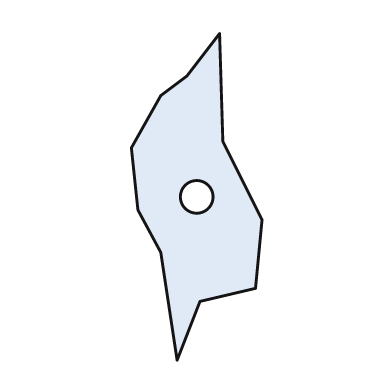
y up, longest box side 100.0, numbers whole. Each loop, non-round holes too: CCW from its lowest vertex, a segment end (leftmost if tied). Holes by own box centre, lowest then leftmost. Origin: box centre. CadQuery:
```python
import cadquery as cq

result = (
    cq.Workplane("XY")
    .moveTo(-6.0, -50.0)
    .lineTo(1.0, -32.0)
    .lineTo(18.0, -28.0)
    .lineTo(20.0, -7.0)
    .lineTo(8.0, 17.0)
    .lineTo(7.0, 50.0)
    .lineTo(-3.0, 37.0)
    .lineTo(-11.0, 31.0)
    .lineTo(-20.0, 15.0)
    .lineTo(-18.0, -4.0)
    .lineTo(-11.0, -17.0)
    .close()
    .moveTo(0.0, 0.0)
    .circle(5.0)
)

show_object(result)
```